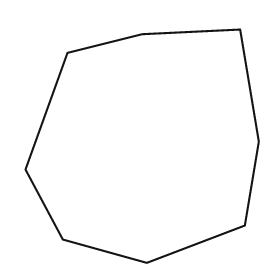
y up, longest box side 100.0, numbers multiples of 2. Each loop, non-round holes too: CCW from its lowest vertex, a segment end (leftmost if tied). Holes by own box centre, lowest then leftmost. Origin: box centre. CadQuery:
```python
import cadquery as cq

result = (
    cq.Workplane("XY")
    .moveTo(2.0, -50.0)
    .lineTo(44.0, -34.0)
    .lineTo(50.0, 2.0)
    .lineTo(42.0, 50.0)
    .lineTo(0.0, 48.0)
    .lineTo(-32.0, 40.0)
    .lineTo(-50.0, -10.0)
    .lineTo(-34.0, -40.0)
    .close()
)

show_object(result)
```